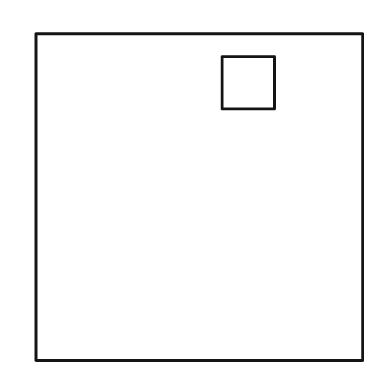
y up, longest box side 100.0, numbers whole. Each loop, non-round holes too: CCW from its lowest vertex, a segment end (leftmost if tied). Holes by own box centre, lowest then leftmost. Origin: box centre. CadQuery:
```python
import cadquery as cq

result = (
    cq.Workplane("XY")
    .moveTo(-50.0, -50.0)
    .lineTo(50.0, -50.0)
    .lineTo(50.0, 50.0)
    .lineTo(-50.0, 50.0)
    .close()
    .moveTo(7.0, 27.0)
    .lineTo(23.0, 27.0)
    .lineTo(23.0, 43.0)
    .lineTo(7.0, 43.0)
    .close()
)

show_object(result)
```